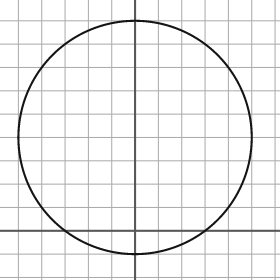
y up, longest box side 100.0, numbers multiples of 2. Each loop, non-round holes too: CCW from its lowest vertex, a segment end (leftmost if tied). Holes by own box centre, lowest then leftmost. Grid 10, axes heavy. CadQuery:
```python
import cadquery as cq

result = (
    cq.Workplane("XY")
    .moveTo(0.0, 40.0)
    .circle(50.0)
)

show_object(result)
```